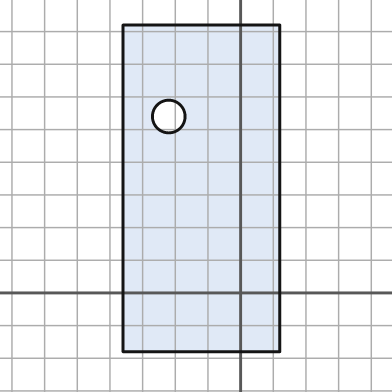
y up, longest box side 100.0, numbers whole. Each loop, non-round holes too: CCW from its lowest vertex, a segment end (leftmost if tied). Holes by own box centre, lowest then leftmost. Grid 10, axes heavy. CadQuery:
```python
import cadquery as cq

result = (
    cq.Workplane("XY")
    .moveTo(-36.0, -18.0)
    .lineTo(12.0, -18.0)
    .lineTo(12.0, 82.0)
    .lineTo(-36.0, 82.0)
    .close()
    .moveTo(-22.0, 54.0)
    .circle(5.0)
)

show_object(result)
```